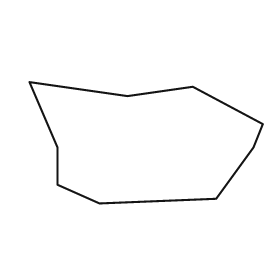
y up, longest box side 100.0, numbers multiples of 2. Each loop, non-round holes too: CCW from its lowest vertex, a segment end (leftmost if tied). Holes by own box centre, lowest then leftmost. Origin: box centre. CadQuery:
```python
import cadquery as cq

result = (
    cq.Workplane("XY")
    .moveTo(-20.0, -26.0)
    .lineTo(30.0, -24.0)
    .lineTo(46.0, -2.0)
    .lineTo(50.0, 8.0)
    .lineTo(20.0, 24.0)
    .lineTo(-8.0, 20.0)
    .lineTo(-50.0, 26.0)
    .lineTo(-38.0, -2.0)
    .lineTo(-38.0, -18.0)
    .close()
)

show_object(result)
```